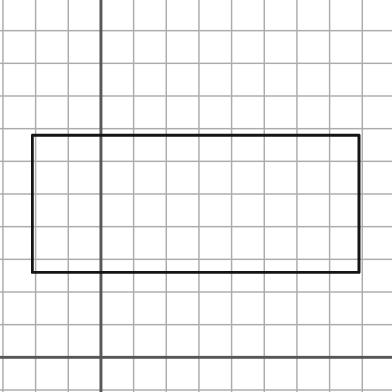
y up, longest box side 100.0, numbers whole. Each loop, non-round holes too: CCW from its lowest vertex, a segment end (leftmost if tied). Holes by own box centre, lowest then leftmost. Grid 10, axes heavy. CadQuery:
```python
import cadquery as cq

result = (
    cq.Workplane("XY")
    .moveTo(-21.0, 26.0)
    .lineTo(79.0, 26.0)
    .lineTo(79.0, 68.0)
    .lineTo(-21.0, 68.0)
    .close()
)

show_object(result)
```